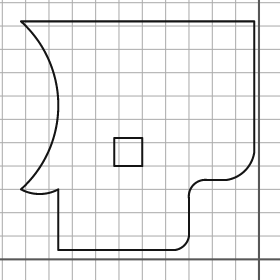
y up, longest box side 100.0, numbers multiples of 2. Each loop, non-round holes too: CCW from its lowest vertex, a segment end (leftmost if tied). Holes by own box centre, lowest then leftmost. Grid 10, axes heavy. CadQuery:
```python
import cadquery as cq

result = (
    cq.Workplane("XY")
    .moveTo(-86.0, 4.0)
    .lineTo(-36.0, 4.0)
    .threePointArc((-32.0, 6.0), (-30.0, 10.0))
    .lineTo(-30.0, 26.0)
    .threePointArc((-28.0, 32.0), (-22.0, 34.0))
    .lineTo(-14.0, 34.0)
    .threePointArc((-6.0, 38.0), (-2.0, 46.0))
    .lineTo(-2.0, 102.0)
    .lineTo(-102.0, 102.0)
    .threePointArc((-86.0, 66.0), (-102.0, 30.0))
    .threePointArc((-94.0, 28.0), (-86.0, 30.0))
    .close()
    .moveTo(-62.0, 40.0)
    .lineTo(-50.0, 40.0)
    .lineTo(-50.0, 52.0)
    .lineTo(-62.0, 52.0)
    .close()
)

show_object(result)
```